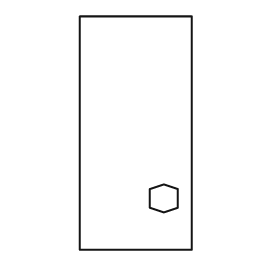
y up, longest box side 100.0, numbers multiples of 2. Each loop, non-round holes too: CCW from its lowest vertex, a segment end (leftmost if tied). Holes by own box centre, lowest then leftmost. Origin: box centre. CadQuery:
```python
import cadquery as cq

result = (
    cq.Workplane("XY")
    .moveTo(-24.0, -50.0)
    .lineTo(24.0, -50.0)
    .lineTo(24.0, 50.0)
    .lineTo(-24.0, 50.0)
    .close()
    .moveTo(12.0, -34.0)
    .lineTo(18.0, -32.0)
    .lineTo(18.0, -24.0)
    .lineTo(12.0, -22.0)
    .lineTo(6.0, -24.0)
    .lineTo(6.0, -32.0)
    .close()
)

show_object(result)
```